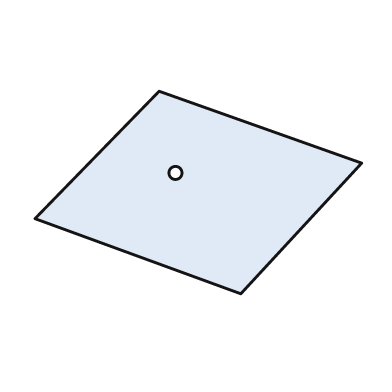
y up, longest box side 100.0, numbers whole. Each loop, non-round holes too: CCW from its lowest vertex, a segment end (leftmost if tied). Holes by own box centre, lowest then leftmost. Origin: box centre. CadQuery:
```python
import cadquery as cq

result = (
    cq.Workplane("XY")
    .moveTo(13.0, -31.0)
    .lineTo(50.0, 9.0)
    .lineTo(-12.0, 31.0)
    .lineTo(-50.0, -8.0)
    .close()
    .moveTo(-7.0, 6.0)
    .circle(2.0)
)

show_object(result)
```